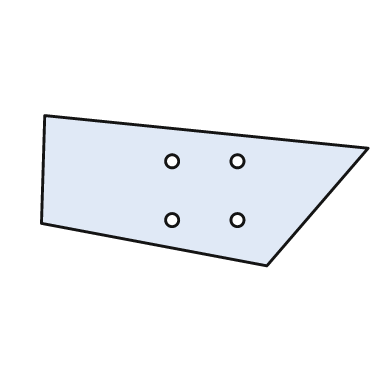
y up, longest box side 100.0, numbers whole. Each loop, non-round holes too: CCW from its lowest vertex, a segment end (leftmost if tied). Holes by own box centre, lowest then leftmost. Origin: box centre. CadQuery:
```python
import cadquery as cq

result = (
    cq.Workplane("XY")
    .moveTo(19.0, -23.0)
    .lineTo(50.0, 13.0)
    .lineTo(-49.0, 23.0)
    .lineTo(-50.0, -10.0)
    .close()
    .moveTo(-10.0, -9.0)
    .circle(2.0)
    .moveTo(10.0, -9.0)
    .circle(2.0)
    .moveTo(-10.0, 9.0)
    .circle(2.0)
    .moveTo(10.0, 9.0)
    .circle(2.0)
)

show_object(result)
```